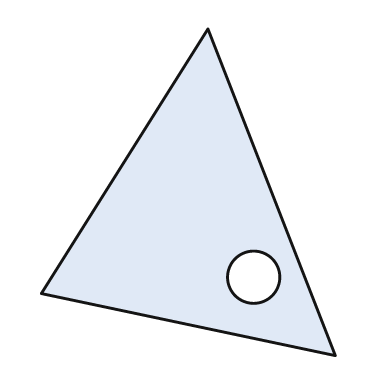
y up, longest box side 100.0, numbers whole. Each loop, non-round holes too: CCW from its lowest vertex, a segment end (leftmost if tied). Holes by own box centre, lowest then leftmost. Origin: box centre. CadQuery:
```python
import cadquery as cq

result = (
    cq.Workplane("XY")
    .moveTo(45.0, -50.0)
    .lineTo(6.0, 50.0)
    .lineTo(-45.0, -31.0)
    .close()
    .moveTo(20.0, -26.0)
    .circle(8.0)
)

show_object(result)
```